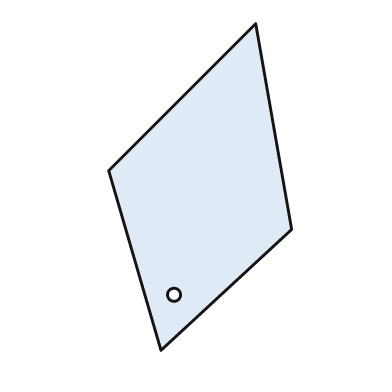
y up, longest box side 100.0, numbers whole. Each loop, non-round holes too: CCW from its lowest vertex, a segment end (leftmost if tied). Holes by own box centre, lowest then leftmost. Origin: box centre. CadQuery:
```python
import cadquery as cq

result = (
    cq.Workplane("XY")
    .moveTo(-12.0, -50.0)
    .lineTo(28.0, -13.0)
    .lineTo(17.0, 50.0)
    .lineTo(-28.0, 5.0)
    .close()
    .moveTo(-8.0, -33.0)
    .circle(2.0)
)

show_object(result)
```